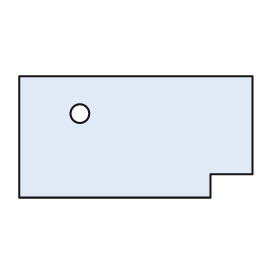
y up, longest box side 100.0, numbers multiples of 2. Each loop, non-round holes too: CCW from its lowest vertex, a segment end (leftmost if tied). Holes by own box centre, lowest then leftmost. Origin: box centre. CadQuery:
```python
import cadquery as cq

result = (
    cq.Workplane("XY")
    .moveTo(-50.0, -26.0)
    .lineTo(32.0, -26.0)
    .lineTo(32.0, -16.0)
    .lineTo(50.0, -16.0)
    .lineTo(50.0, 26.0)
    .lineTo(-50.0, 26.0)
    .close()
    .moveTo(-24.0, 10.0)
    .circle(4.0)
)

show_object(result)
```